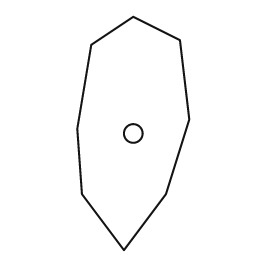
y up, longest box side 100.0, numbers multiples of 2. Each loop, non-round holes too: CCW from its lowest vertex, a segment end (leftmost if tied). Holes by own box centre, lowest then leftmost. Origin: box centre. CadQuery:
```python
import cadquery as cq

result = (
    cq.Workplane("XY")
    .moveTo(-4.0, -50.0)
    .lineTo(14.0, -26.0)
    .lineTo(24.0, 6.0)
    .lineTo(20.0, 40.0)
    .lineTo(0.0, 50.0)
    .lineTo(-18.0, 38.0)
    .lineTo(-24.0, 2.0)
    .lineTo(-22.0, -26.0)
    .close()
    .moveTo(0.0, 0.0)
    .circle(4.0)
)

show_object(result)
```